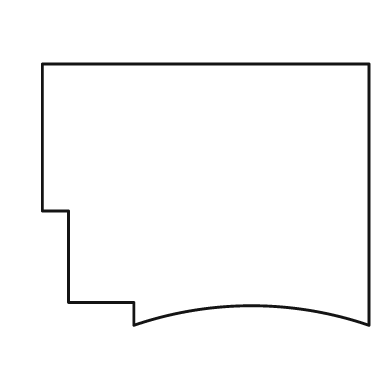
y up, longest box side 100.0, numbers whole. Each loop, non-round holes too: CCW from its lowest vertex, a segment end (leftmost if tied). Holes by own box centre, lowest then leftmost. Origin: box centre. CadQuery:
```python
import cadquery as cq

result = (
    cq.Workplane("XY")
    .moveTo(-22.0, -40.0)
    .threePointArc((14.0, -34.0), (50.0, -40.0))
    .lineTo(50.0, 40.0)
    .lineTo(-50.0, 40.0)
    .lineTo(-50.0, -5.0)
    .lineTo(-42.0, -5.0)
    .lineTo(-42.0, -33.0)
    .lineTo(-22.0, -33.0)
    .close()
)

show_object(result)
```